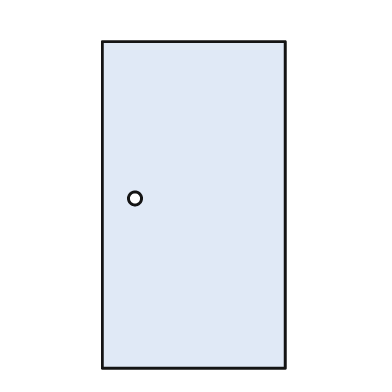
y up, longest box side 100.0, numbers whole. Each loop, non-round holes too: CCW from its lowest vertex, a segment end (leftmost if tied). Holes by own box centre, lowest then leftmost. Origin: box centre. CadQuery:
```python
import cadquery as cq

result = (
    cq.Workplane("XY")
    .moveTo(-28.0, -50.0)
    .lineTo(28.0, -50.0)
    .lineTo(28.0, 50.0)
    .lineTo(-28.0, 50.0)
    .close()
    .moveTo(-18.0, 2.0)
    .circle(2.0)
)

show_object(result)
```